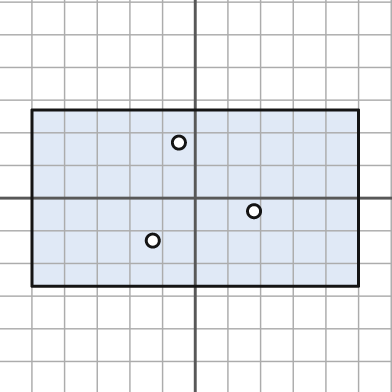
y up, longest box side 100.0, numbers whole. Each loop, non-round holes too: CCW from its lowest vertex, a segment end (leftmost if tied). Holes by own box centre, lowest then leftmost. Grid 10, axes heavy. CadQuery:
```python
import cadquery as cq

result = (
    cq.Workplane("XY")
    .moveTo(-50.0, -27.0)
    .lineTo(50.0, -27.0)
    .lineTo(50.0, 27.0)
    .lineTo(-50.0, 27.0)
    .close()
    .moveTo(-13.0, -13.0)
    .circle(2.0)
    .moveTo(18.0, -4.0)
    .circle(2.0)
    .moveTo(-5.0, 17.0)
    .circle(2.0)
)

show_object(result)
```